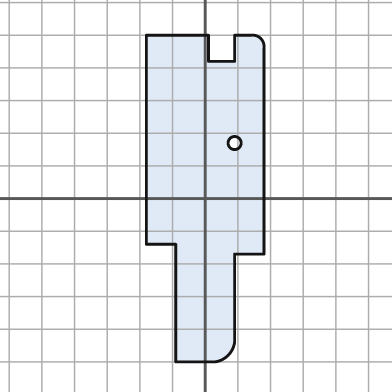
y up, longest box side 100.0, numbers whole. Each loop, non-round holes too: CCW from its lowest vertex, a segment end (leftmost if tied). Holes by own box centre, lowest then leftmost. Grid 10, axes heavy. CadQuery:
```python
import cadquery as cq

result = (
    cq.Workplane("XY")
    .moveTo(-9.0, -50.0)
    .lineTo(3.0, -50.0)
    .threePointArc((7.0, -48.0), (9.0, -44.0))
    .lineTo(9.0, -17.0)
    .lineTo(18.0, -17.0)
    .lineTo(18.0, 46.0)
    .threePointArc((17.0, 49.0), (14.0, 50.0))
    .lineTo(9.0, 50.0)
    .lineTo(9.0, 42.0)
    .lineTo(1.0, 42.0)
    .lineTo(1.0, 50.0)
    .lineTo(-18.0, 50.0)
    .lineTo(-18.0, -14.0)
    .lineTo(-9.0, -14.0)
    .close()
    .moveTo(9.0, 17.0)
    .circle(2.0)
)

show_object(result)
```